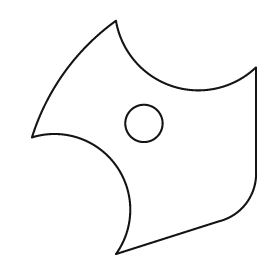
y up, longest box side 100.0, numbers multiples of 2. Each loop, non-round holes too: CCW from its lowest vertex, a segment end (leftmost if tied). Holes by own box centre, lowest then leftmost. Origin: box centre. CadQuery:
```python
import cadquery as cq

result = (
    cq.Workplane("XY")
    .moveTo(-12.0, -50.0)
    .lineTo(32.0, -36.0)
    .threePointArc((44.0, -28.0), (48.0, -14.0))
    .lineTo(48.0, 30.0)
    .threePointArc((12.0, 22.0), (-12.0, 50.0))
    .threePointArc((-34.0, 28.0), (-48.0, 0.0))
    .threePointArc((-12.0, -12.0), (-12.0, -50.0))
    .close()
    .moveTo(0.0, 6.0)
    .circle(8.0)
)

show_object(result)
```